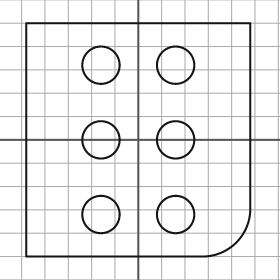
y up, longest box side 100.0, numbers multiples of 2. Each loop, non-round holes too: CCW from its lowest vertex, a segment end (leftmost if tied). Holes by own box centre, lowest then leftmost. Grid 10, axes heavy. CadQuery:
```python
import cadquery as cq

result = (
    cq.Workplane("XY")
    .moveTo(-48.0, -50.0)
    .lineTo(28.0, -50.0)
    .threePointArc((42.0, -44.0), (48.0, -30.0))
    .lineTo(48.0, 50.0)
    .lineTo(-48.0, 50.0)
    .close()
    .moveTo(-16.0, -32.0)
    .circle(8.0)
    .moveTo(16.0, -32.0)
    .circle(8.0)
    .moveTo(-16.0, 0.0)
    .circle(8.0)
    .moveTo(16.0, 0.0)
    .circle(8.0)
    .moveTo(-16.0, 32.0)
    .circle(8.0)
    .moveTo(16.0, 32.0)
    .circle(8.0)
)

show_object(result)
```